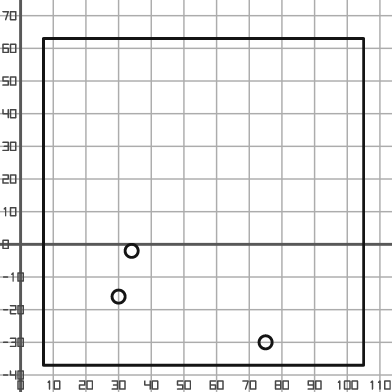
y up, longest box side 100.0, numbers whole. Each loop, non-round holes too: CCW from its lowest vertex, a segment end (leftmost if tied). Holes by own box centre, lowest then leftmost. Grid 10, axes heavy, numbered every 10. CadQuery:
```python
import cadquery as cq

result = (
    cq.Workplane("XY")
    .moveTo(7.0, -37.0)
    .lineTo(105.0, -37.0)
    .lineTo(105.0, 63.0)
    .lineTo(7.0, 63.0)
    .close()
    .moveTo(75.0, -30.0)
    .circle(2.0)
    .moveTo(30.0, -16.0)
    .circle(2.0)
    .moveTo(34.0, -2.0)
    .circle(2.0)
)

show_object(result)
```